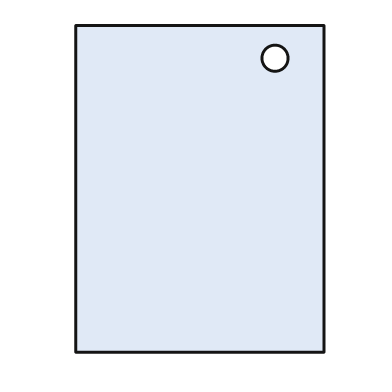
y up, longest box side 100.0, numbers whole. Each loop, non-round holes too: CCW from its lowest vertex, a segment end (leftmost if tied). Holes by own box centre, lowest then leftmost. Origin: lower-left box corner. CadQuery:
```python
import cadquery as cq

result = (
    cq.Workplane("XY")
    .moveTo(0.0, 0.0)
    .lineTo(76.0, 0.0)
    .lineTo(76.0, 100.0)
    .lineTo(0.0, 100.0)
    .close()
    .moveTo(61.0, 90.0)
    .circle(4.0)
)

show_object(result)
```